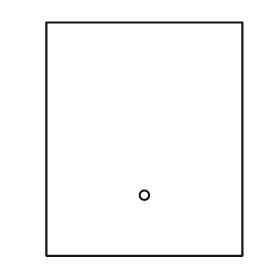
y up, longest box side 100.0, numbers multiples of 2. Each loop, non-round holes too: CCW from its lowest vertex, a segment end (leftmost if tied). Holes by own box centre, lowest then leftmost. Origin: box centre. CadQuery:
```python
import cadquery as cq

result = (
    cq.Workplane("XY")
    .moveTo(-42.0, -50.0)
    .lineTo(42.0, -50.0)
    .lineTo(42.0, 50.0)
    .lineTo(-42.0, 50.0)
    .close()
    .moveTo(0.0, -24.0)
    .circle(2.0)
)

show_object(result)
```